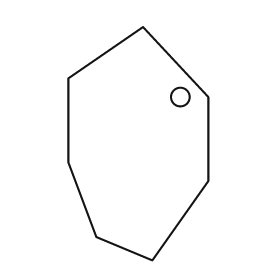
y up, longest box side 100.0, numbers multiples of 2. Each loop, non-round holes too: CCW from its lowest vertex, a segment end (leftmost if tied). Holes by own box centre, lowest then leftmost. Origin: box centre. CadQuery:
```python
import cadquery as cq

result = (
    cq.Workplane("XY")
    .moveTo(6.0, -50.0)
    .lineTo(30.0, -16.0)
    .lineTo(30.0, 20.0)
    .lineTo(2.0, 50.0)
    .lineTo(-30.0, 28.0)
    .lineTo(-30.0, -8.0)
    .lineTo(-18.0, -40.0)
    .close()
    .moveTo(18.0, 20.0)
    .circle(4.0)
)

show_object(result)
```